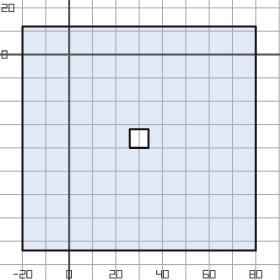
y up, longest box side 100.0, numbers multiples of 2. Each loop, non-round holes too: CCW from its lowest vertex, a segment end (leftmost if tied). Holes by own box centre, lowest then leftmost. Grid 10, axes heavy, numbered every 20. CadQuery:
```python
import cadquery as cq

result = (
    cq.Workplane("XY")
    .moveTo(-20.0, -84.0)
    .lineTo(80.0, -84.0)
    .lineTo(80.0, 12.0)
    .lineTo(-20.0, 12.0)
    .close()
    .moveTo(26.0, -40.0)
    .lineTo(34.0, -40.0)
    .lineTo(34.0, -32.0)
    .lineTo(26.0, -32.0)
    .close()
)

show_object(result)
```